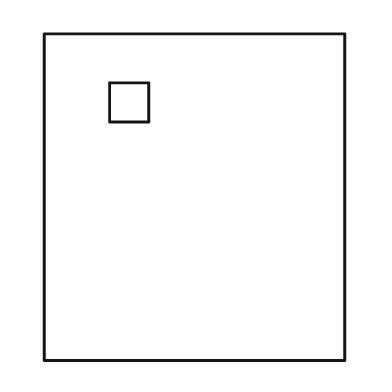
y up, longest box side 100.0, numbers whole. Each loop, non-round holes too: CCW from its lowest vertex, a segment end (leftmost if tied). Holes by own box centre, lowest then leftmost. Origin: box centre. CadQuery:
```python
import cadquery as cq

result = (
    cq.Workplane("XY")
    .moveTo(-46.0, -50.0)
    .lineTo(46.0, -50.0)
    .lineTo(46.0, 50.0)
    .lineTo(-46.0, 50.0)
    .close()
    .moveTo(-26.0, 23.0)
    .lineTo(-14.0, 23.0)
    .lineTo(-14.0, 35.0)
    .lineTo(-26.0, 35.0)
    .close()
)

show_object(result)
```